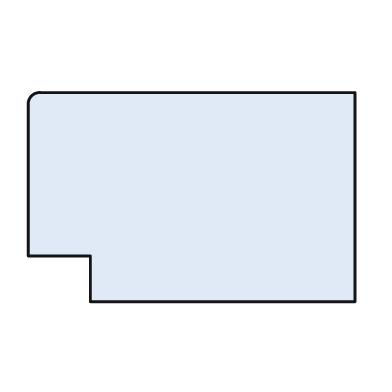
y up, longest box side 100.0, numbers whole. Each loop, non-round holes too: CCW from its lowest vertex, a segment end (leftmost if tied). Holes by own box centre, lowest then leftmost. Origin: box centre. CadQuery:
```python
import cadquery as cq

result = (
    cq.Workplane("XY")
    .moveTo(-31.0, -32.0)
    .lineTo(50.0, -32.0)
    .lineTo(50.0, 32.0)
    .lineTo(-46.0, 32.0)
    .threePointArc((-49.0, 31.0), (-50.0, 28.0))
    .lineTo(-50.0, -18.0)
    .lineTo(-31.0, -18.0)
    .close()
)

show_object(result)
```